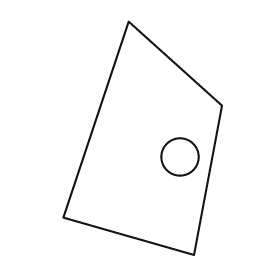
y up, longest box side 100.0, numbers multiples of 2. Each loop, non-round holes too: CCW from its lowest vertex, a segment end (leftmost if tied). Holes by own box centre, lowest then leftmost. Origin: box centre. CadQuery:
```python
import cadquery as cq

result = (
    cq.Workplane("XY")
    .moveTo(22.0, -50.0)
    .lineTo(34.0, 14.0)
    .lineTo(-6.0, 50.0)
    .lineTo(-34.0, -34.0)
    .close()
    .moveTo(16.0, -8.0)
    .circle(8.0)
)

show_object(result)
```